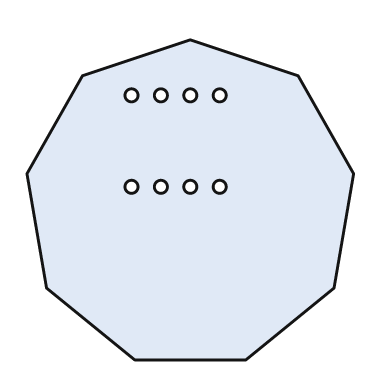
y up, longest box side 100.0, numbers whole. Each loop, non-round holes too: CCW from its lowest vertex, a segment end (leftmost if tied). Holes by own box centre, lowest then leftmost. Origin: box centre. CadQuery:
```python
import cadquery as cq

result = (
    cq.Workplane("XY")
    .moveTo(-17.0, -49.0)
    .lineTo(17.0, -49.0)
    .lineTo(44.0, -27.0)
    .lineTo(50.0, 8.0)
    .lineTo(33.0, 38.0)
    .lineTo(0.0, 49.0)
    .lineTo(-33.0, 38.0)
    .lineTo(-50.0, 8.0)
    .lineTo(-44.0, -27.0)
    .close()
    .moveTo(-18.0, 4.0)
    .circle(2.0)
    .moveTo(-9.0, 4.0)
    .circle(2.0)
    .moveTo(0.0, 4.0)
    .circle(2.0)
    .moveTo(9.0, 4.0)
    .circle(2.0)
    .moveTo(-18.0, 32.0)
    .circle(2.0)
    .moveTo(-9.0, 32.0)
    .circle(2.0)
    .moveTo(0.0, 32.0)
    .circle(2.0)
    .moveTo(9.0, 32.0)
    .circle(2.0)
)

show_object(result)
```